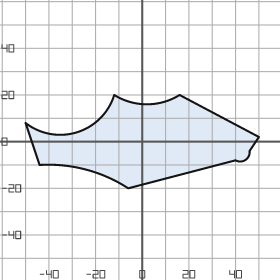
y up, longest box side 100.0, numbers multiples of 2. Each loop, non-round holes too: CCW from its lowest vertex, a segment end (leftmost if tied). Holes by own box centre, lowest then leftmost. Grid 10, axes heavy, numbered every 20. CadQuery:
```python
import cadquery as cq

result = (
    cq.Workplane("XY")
    .moveTo(-6.0, -20.0)
    .lineTo(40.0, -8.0)
    .threePointArc((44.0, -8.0), (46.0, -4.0))
    .lineTo(50.0, 2.0)
    .lineTo(16.0, 20.0)
    .threePointArc((2.0, 16.0), (-12.0, 20.0))
    .threePointArc((-28.0, 4.0), (-50.0, 8.0))
    .lineTo(-44.0, -10.0)
    .threePointArc((-24.0, -12.0), (-6.0, -20.0))
    .close()
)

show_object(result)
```